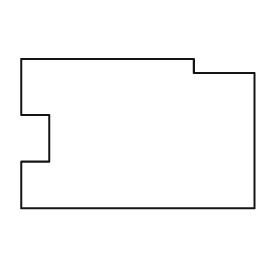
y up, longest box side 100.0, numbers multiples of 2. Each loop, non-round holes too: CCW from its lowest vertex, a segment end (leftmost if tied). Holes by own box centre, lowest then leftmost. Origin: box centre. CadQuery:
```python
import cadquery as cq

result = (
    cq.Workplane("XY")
    .moveTo(-50.0, -32.0)
    .lineTo(50.0, -32.0)
    .lineTo(50.0, 26.0)
    .lineTo(24.0, 26.0)
    .lineTo(24.0, 32.0)
    .lineTo(-50.0, 32.0)
    .lineTo(-50.0, 8.0)
    .lineTo(-38.0, 8.0)
    .lineTo(-38.0, -12.0)
    .lineTo(-50.0, -12.0)
    .close()
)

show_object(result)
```